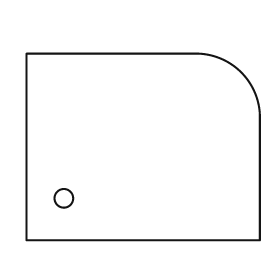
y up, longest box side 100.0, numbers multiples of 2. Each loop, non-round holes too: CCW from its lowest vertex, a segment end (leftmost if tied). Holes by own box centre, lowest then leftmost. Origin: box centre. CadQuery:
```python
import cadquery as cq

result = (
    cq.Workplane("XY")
    .moveTo(-50.0, -40.0)
    .lineTo(50.0, -40.0)
    .lineTo(50.0, 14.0)
    .threePointArc((42.0, 32.0), (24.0, 40.0))
    .lineTo(-50.0, 40.0)
    .close()
    .moveTo(-34.0, -22.0)
    .circle(4.0)
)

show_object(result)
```